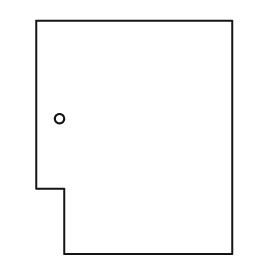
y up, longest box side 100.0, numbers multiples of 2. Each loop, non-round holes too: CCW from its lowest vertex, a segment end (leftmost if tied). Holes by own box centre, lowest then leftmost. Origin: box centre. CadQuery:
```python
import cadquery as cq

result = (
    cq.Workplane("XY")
    .moveTo(-30.0, -50.0)
    .lineTo(42.0, -50.0)
    .lineTo(42.0, 50.0)
    .lineTo(-42.0, 50.0)
    .lineTo(-42.0, -22.0)
    .lineTo(-30.0, -22.0)
    .close()
    .moveTo(-32.0, 8.0)
    .circle(2.0)
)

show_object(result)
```